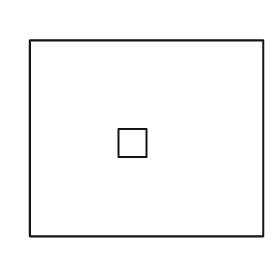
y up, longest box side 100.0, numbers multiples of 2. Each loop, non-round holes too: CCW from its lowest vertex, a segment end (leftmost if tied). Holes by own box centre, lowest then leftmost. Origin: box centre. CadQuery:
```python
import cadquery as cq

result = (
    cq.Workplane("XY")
    .moveTo(-50.0, -42.0)
    .lineTo(50.0, -42.0)
    .lineTo(50.0, 42.0)
    .lineTo(-50.0, 42.0)
    .close()
    .moveTo(-12.0, -8.0)
    .lineTo(0.0, -8.0)
    .lineTo(0.0, 4.0)
    .lineTo(-12.0, 4.0)
    .close()
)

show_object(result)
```